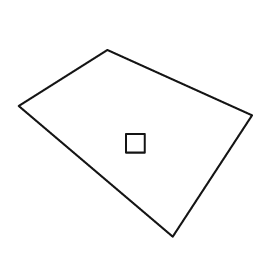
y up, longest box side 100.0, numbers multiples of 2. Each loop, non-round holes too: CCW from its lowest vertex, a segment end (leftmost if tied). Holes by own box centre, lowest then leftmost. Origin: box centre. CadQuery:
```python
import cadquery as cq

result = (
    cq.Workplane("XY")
    .moveTo(16.0, -40.0)
    .lineTo(50.0, 12.0)
    .lineTo(-12.0, 40.0)
    .lineTo(-50.0, 16.0)
    .close()
    .moveTo(-4.0, -4.0)
    .lineTo(4.0, -4.0)
    .lineTo(4.0, 4.0)
    .lineTo(-4.0, 4.0)
    .close()
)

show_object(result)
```